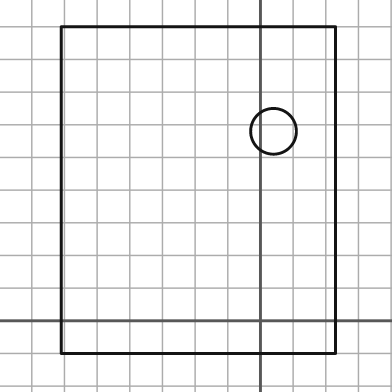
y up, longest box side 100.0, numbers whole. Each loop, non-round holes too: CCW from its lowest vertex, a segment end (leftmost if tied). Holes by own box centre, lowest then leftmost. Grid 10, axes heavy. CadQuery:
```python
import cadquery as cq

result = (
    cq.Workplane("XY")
    .moveTo(-61.0, -10.0)
    .lineTo(23.0, -10.0)
    .lineTo(23.0, 90.0)
    .lineTo(-61.0, 90.0)
    .close()
    .moveTo(4.0, 58.0)
    .circle(7.0)
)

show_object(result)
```